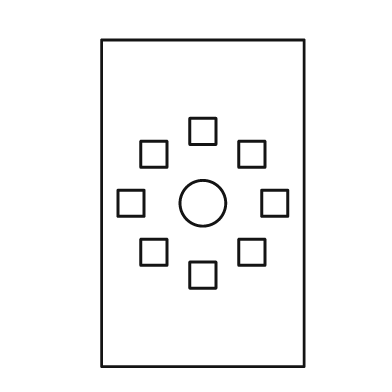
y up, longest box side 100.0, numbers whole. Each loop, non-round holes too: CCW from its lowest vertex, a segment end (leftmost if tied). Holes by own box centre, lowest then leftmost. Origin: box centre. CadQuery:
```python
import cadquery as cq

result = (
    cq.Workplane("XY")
    .moveTo(-31.0, -50.0)
    .lineTo(31.0, -50.0)
    .lineTo(31.0, 50.0)
    .lineTo(-31.0, 50.0)
    .close()
    .moveTo(-4.0, -26.0)
    .lineTo(4.0, -26.0)
    .lineTo(4.0, -18.0)
    .lineTo(-4.0, -18.0)
    .close()
    .moveTo(-19.0, -19.0)
    .lineTo(-11.0, -19.0)
    .lineTo(-11.0, -11.0)
    .lineTo(-19.0, -11.0)
    .close()
    .moveTo(11.0, -19.0)
    .lineTo(19.0, -19.0)
    .lineTo(19.0, -11.0)
    .lineTo(11.0, -11.0)
    .close()
    .moveTo(-26.0, -4.0)
    .lineTo(-18.0, -4.0)
    .lineTo(-18.0, 4.0)
    .lineTo(-26.0, 4.0)
    .close()
    .moveTo(0.0, 0.0)
    .circle(7.0)
    .moveTo(18.0, -4.0)
    .lineTo(26.0, -4.0)
    .lineTo(26.0, 4.0)
    .lineTo(18.0, 4.0)
    .close()
    .moveTo(-19.0, 11.0)
    .lineTo(-11.0, 11.0)
    .lineTo(-11.0, 19.0)
    .lineTo(-19.0, 19.0)
    .close()
    .moveTo(11.0, 11.0)
    .lineTo(19.0, 11.0)
    .lineTo(19.0, 19.0)
    .lineTo(11.0, 19.0)
    .close()
    .moveTo(-4.0, 18.0)
    .lineTo(4.0, 18.0)
    .lineTo(4.0, 26.0)
    .lineTo(-4.0, 26.0)
    .close()
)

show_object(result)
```